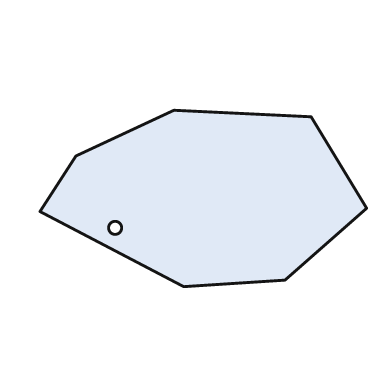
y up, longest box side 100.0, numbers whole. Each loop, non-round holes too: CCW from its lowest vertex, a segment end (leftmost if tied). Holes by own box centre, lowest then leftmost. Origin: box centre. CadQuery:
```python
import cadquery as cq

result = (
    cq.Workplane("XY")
    .moveTo(-6.0, -27.0)
    .lineTo(25.0, -25.0)
    .lineTo(50.0, -3.0)
    .lineTo(33.0, 25.0)
    .lineTo(-9.0, 27.0)
    .lineTo(-39.0, 13.0)
    .lineTo(-50.0, -4.0)
    .close()
    .moveTo(-27.0, -9.0)
    .circle(2.0)
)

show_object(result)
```